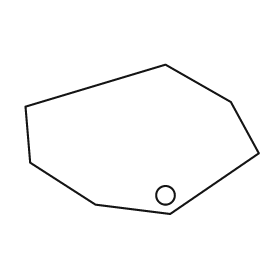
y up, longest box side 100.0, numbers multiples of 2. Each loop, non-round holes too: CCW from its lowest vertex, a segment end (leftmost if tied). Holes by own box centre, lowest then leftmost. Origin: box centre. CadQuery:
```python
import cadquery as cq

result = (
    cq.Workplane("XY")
    .moveTo(12.0, -32.0)
    .lineTo(50.0, -6.0)
    .lineTo(38.0, 16.0)
    .lineTo(10.0, 32.0)
    .lineTo(-50.0, 14.0)
    .lineTo(-48.0, -10.0)
    .lineTo(-20.0, -28.0)
    .close()
    .moveTo(10.0, -24.0)
    .circle(4.0)
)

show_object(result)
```